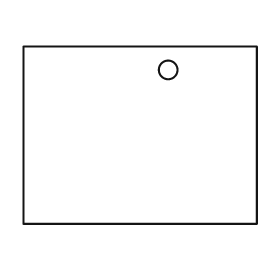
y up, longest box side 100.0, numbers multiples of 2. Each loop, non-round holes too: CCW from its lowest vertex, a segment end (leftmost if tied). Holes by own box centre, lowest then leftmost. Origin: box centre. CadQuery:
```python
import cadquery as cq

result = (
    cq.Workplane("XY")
    .moveTo(-50.0, -38.0)
    .lineTo(50.0, -38.0)
    .lineTo(50.0, 38.0)
    .lineTo(-50.0, 38.0)
    .close()
    .moveTo(12.0, 28.0)
    .circle(4.0)
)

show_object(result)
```